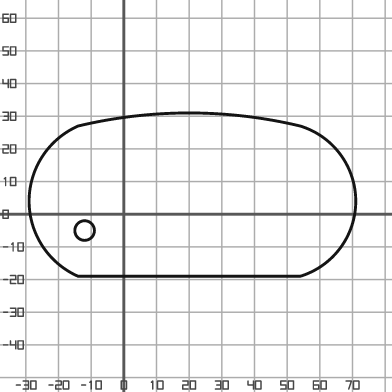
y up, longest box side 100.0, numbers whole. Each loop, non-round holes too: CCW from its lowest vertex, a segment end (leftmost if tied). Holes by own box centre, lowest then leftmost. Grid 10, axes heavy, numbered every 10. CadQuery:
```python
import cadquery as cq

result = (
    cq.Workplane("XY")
    .moveTo(-14.0, -19.0)
    .lineTo(54.0, -19.0)
    .threePointArc((71.0, 4.0), (54.0, 27.0))
    .threePointArc((20.0, 31.0), (-14.0, 27.0))
    .threePointArc((-29.0, 4.0), (-14.0, -19.0))
    .close()
    .moveTo(-12.0, -5.0)
    .circle(3.0)
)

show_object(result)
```